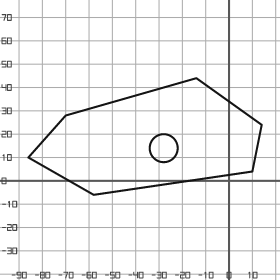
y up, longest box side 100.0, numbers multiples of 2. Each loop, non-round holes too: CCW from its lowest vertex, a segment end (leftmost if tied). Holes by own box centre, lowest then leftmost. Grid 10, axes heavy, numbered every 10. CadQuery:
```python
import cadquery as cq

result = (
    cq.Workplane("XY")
    .moveTo(-58.0, -6.0)
    .lineTo(10.0, 4.0)
    .lineTo(14.0, 24.0)
    .lineTo(-14.0, 44.0)
    .lineTo(-70.0, 28.0)
    .lineTo(-86.0, 10.0)
    .close()
    .moveTo(-28.0, 14.0)
    .circle(6.0)
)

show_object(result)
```